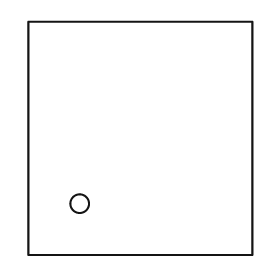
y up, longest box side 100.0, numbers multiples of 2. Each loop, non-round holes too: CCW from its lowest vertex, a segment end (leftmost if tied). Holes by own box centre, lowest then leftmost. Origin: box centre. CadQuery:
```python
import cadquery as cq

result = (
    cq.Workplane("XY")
    .moveTo(-48.0, -50.0)
    .lineTo(48.0, -50.0)
    .lineTo(48.0, 50.0)
    .lineTo(-48.0, 50.0)
    .close()
    .moveTo(-26.0, -28.0)
    .circle(4.0)
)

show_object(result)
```